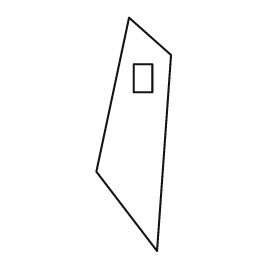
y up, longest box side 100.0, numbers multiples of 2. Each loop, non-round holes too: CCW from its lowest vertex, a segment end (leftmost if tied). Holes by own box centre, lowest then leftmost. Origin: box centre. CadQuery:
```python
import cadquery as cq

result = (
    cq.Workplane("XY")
    .moveTo(10.0, -50.0)
    .lineTo(16.0, 34.0)
    .lineTo(-2.0, 50.0)
    .lineTo(-16.0, -16.0)
    .close()
    .moveTo(0.0, 18.0)
    .lineTo(8.0, 18.0)
    .lineTo(8.0, 30.0)
    .lineTo(0.0, 30.0)
    .close()
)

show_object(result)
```